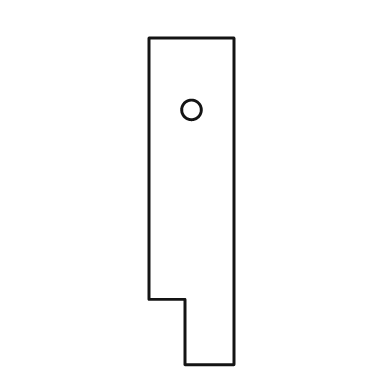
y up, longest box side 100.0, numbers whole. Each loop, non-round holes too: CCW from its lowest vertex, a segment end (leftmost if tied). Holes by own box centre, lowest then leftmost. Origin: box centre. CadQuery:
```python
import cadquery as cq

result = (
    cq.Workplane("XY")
    .moveTo(-2.0, -50.0)
    .lineTo(13.0, -50.0)
    .lineTo(13.0, 50.0)
    .lineTo(-13.0, 50.0)
    .lineTo(-13.0, -30.0)
    .lineTo(-2.0, -30.0)
    .close()
    .moveTo(0.0, 28.0)
    .circle(3.0)
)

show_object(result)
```